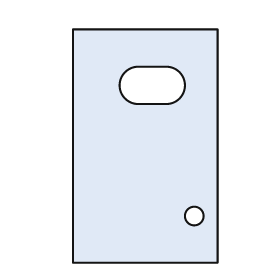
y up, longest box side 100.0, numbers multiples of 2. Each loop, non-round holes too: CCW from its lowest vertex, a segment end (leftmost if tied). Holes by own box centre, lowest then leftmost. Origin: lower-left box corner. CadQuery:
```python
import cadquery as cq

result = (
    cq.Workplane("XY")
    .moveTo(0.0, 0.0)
    .lineTo(62.0, 0.0)
    .lineTo(62.0, 100.0)
    .lineTo(0.0, 100.0)
    .close()
    .moveTo(52.0, 20.0)
    .circle(4.0)
    .moveTo(28.0, 68.0)
    .lineTo(40.0, 68.0)
    .threePointArc((48.0, 76.0), (40.0, 84.0))
    .lineTo(28.0, 84.0)
    .threePointArc((20.0, 76.0), (28.0, 68.0))
    .close()
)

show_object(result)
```